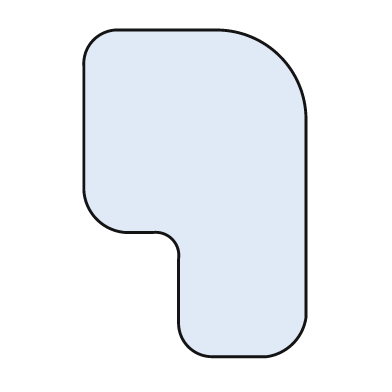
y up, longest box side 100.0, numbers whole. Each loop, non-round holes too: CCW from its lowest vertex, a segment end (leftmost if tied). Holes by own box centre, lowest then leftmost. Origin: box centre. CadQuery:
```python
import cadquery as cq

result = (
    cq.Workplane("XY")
    .moveTo(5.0, -50.0)
    .lineTo(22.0, -50.0)
    .threePointArc((30.0, -46.0), (34.0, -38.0))
    .lineTo(34.0, 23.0)
    .threePointArc((26.0, 42.0), (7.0, 50.0))
    .lineTo(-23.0, 50.0)
    .threePointArc((-31.0, 47.0), (-34.0, 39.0))
    .lineTo(-34.0, 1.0)
    .threePointArc((-30.0, -8.0), (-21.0, -12.0))
    .lineTo(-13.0, -12.0)
    .threePointArc((-7.0, -14.0), (-5.0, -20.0))
    .lineTo(-5.0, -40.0)
    .threePointArc((-2.0, -47.0), (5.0, -50.0))
    .close()
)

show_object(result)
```